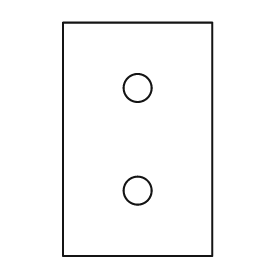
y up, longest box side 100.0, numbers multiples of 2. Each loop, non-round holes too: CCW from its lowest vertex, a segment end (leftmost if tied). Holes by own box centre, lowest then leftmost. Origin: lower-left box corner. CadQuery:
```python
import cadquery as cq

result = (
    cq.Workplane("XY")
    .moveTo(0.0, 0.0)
    .lineTo(64.0, 0.0)
    .lineTo(64.0, 100.0)
    .lineTo(0.0, 100.0)
    .close()
    .moveTo(32.0, 28.0)
    .circle(6.0)
    .moveTo(32.0, 72.0)
    .circle(6.0)
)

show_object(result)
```